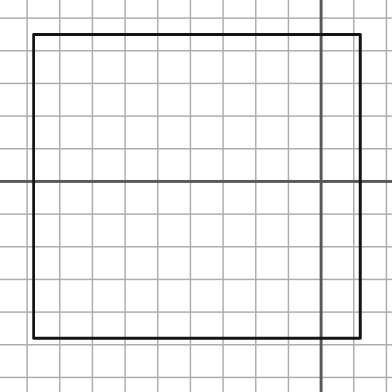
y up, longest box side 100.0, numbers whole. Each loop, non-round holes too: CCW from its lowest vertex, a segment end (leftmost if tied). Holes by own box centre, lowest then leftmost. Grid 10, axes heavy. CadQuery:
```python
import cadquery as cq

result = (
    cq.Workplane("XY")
    .moveTo(-88.0, -48.0)
    .lineTo(12.0, -48.0)
    .lineTo(12.0, 45.0)
    .lineTo(-88.0, 45.0)
    .close()
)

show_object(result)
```